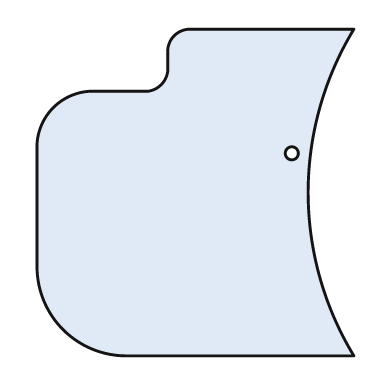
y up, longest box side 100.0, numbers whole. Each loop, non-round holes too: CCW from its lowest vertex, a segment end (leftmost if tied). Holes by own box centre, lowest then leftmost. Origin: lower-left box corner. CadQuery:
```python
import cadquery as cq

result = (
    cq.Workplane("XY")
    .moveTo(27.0, 0.0)
    .lineTo(97.0, 0.0)
    .threePointArc((83.0, 50.0), (97.0, 100.0))
    .lineTo(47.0, 100.0)
    .threePointArc((42.0, 98.0), (40.0, 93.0))
    .lineTo(40.0, 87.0)
    .threePointArc((38.0, 83.0), (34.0, 81.0))
    .lineTo(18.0, 81.0)
    .threePointArc((5.0, 76.0), (0.0, 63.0))
    .lineTo(0.0, 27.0)
    .threePointArc((8.0, 8.0), (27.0, 0.0))
    .close()
    .moveTo(78.0, 62.0)
    .circle(2.0)
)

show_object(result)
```